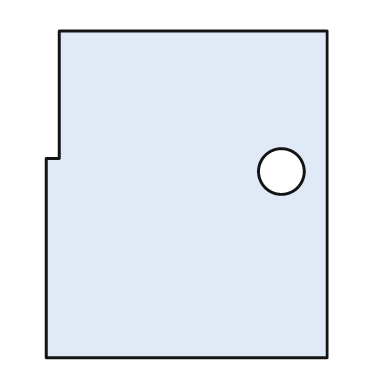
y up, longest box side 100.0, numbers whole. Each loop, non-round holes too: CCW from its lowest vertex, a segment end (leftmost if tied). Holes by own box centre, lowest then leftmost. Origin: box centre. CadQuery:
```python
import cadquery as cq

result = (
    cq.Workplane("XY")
    .moveTo(-43.0, -50.0)
    .lineTo(43.0, -50.0)
    .lineTo(43.0, 50.0)
    .lineTo(-39.0, 50.0)
    .lineTo(-39.0, 11.0)
    .lineTo(-43.0, 11.0)
    .close()
    .moveTo(29.0, 7.0)
    .circle(7.0)
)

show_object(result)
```